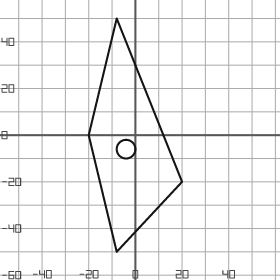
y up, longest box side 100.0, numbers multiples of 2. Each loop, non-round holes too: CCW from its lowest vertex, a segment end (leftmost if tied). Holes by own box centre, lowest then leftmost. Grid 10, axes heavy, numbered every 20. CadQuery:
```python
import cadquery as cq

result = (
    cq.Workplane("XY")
    .moveTo(-8.0, -50.0)
    .lineTo(20.0, -20.0)
    .lineTo(-8.0, 50.0)
    .lineTo(-20.0, 0.0)
    .close()
    .moveTo(-4.0, -6.0)
    .circle(4.0)
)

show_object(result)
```